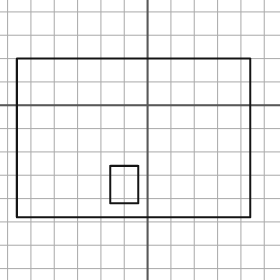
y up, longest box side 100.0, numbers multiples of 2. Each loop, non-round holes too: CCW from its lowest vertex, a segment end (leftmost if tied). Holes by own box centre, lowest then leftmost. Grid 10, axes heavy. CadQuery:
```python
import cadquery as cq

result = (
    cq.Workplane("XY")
    .moveTo(-56.0, -48.0)
    .lineTo(44.0, -48.0)
    .lineTo(44.0, 20.0)
    .lineTo(-56.0, 20.0)
    .close()
    .moveTo(-16.0, -42.0)
    .lineTo(-4.0, -42.0)
    .lineTo(-4.0, -26.0)
    .lineTo(-16.0, -26.0)
    .close()
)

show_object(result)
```